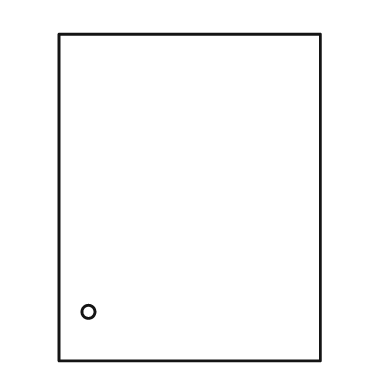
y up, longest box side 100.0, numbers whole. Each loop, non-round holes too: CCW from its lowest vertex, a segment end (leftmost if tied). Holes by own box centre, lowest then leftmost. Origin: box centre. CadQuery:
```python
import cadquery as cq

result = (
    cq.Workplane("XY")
    .moveTo(-40.0, -50.0)
    .lineTo(40.0, -50.0)
    .lineTo(40.0, 50.0)
    .lineTo(-40.0, 50.0)
    .close()
    .moveTo(-31.0, -35.0)
    .circle(2.0)
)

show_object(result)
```